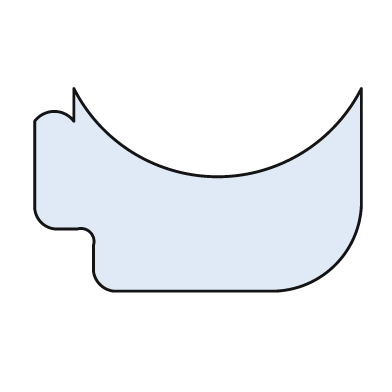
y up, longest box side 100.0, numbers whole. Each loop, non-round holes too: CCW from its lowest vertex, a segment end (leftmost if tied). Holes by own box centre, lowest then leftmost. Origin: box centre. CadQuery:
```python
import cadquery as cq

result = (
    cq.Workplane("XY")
    .moveTo(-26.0, -31.0)
    .lineTo(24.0, -31.0)
    .threePointArc((42.0, -23.0), (50.0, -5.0))
    .lineTo(50.0, 31.0)
    .threePointArc((6.0, 4.0), (-38.0, 31.0))
    .lineTo(-38.0, 21.0)
    .threePointArc((-44.0, 24.0), (-50.0, 21.0))
    .lineTo(-50.0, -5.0)
    .threePointArc((-48.0, -10.0), (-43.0, -12.0))
    .lineTo(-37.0, -12.0)
    .threePointArc((-33.0, -13.0), (-32.0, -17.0))
    .lineTo(-32.0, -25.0)
    .threePointArc((-30.0, -29.0), (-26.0, -31.0))
    .close()
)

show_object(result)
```